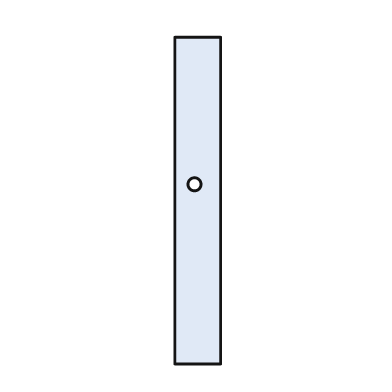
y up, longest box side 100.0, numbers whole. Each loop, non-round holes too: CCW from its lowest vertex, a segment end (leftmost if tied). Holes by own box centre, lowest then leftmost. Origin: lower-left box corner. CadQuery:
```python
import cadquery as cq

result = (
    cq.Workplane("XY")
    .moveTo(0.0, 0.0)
    .lineTo(14.0, 0.0)
    .lineTo(14.0, 100.0)
    .lineTo(0.0, 100.0)
    .close()
    .moveTo(6.0, 55.0)
    .circle(2.0)
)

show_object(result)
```